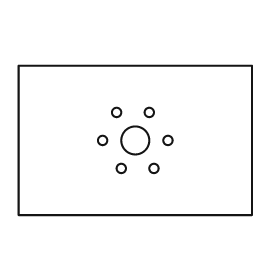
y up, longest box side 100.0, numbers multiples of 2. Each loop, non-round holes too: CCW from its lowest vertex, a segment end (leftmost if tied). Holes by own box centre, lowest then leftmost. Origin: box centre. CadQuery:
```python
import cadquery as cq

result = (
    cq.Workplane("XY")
    .moveTo(-50.0, -32.0)
    .lineTo(50.0, -32.0)
    .lineTo(50.0, 32.0)
    .lineTo(-50.0, 32.0)
    .close()
    .moveTo(-6.0, -12.0)
    .circle(2.0)
    .moveTo(8.0, -12.0)
    .circle(2.0)
    .moveTo(-14.0, 0.0)
    .circle(2.0)
    .moveTo(0.0, 0.0)
    .circle(6.0)
    .moveTo(14.0, 0.0)
    .circle(2.0)
    .moveTo(-8.0, 12.0)
    .circle(2.0)
    .moveTo(6.0, 12.0)
    .circle(2.0)
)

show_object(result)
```